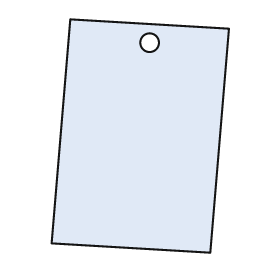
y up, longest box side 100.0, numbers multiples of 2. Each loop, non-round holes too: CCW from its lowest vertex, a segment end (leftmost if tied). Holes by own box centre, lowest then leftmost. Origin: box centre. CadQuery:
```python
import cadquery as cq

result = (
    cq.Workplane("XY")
    .moveTo(30.0, -50.0)
    .lineTo(38.0, 46.0)
    .lineTo(-30.0, 50.0)
    .lineTo(-38.0, -46.0)
    .close()
    .moveTo(4.0, 40.0)
    .circle(4.0)
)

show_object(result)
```